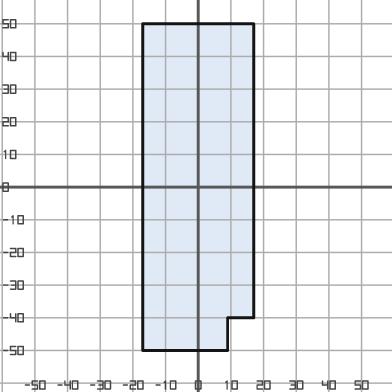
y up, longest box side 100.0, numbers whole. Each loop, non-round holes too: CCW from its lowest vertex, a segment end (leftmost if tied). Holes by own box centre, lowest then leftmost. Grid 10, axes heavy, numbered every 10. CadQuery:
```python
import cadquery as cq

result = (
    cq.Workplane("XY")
    .moveTo(-17.0, -50.0)
    .lineTo(9.0, -50.0)
    .lineTo(9.0, -40.0)
    .lineTo(17.0, -40.0)
    .lineTo(17.0, 50.0)
    .lineTo(-17.0, 50.0)
    .close()
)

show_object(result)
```